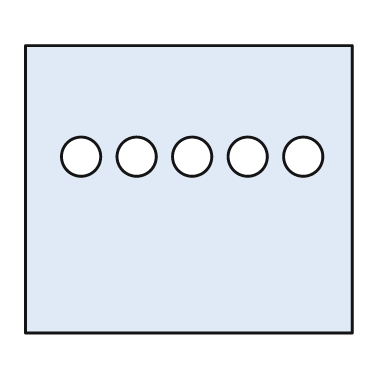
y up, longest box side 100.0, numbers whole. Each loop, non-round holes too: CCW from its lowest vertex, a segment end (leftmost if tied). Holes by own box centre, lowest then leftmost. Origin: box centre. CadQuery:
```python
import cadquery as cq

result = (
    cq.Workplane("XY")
    .moveTo(-50.0, -44.0)
    .lineTo(50.0, -44.0)
    .lineTo(50.0, 44.0)
    .lineTo(-50.0, 44.0)
    .close()
    .moveTo(-33.0, 10.0)
    .circle(6.0)
    .moveTo(-16.0, 10.0)
    .circle(6.0)
    .moveTo(1.0, 10.0)
    .circle(6.0)
    .moveTo(18.0, 10.0)
    .circle(6.0)
    .moveTo(35.0, 10.0)
    .circle(6.0)
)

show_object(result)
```